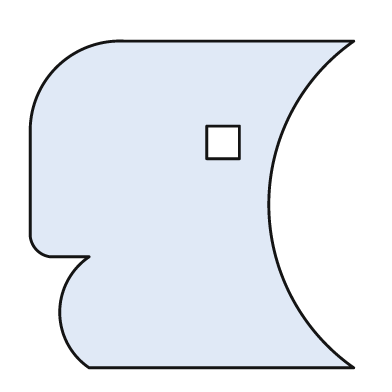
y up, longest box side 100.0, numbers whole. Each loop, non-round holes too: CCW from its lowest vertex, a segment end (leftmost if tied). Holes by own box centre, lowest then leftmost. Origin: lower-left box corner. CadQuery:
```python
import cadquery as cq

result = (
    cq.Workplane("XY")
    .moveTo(18.0, 0.0)
    .lineTo(99.0, 0.0)
    .threePointArc((73.0, 50.0), (99.0, 100.0))
    .lineTo(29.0, 100.0)
    .threePointArc((8.0, 92.0), (0.0, 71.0))
    .lineTo(0.0, 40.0)
    .threePointArc((2.0, 36.0), (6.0, 34.0))
    .lineTo(18.0, 34.0)
    .threePointArc((9.0, 17.0), (18.0, 0.0))
    .close()
    .moveTo(54.0, 64.0)
    .lineTo(64.0, 64.0)
    .lineTo(64.0, 74.0)
    .lineTo(54.0, 74.0)
    .close()
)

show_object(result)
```